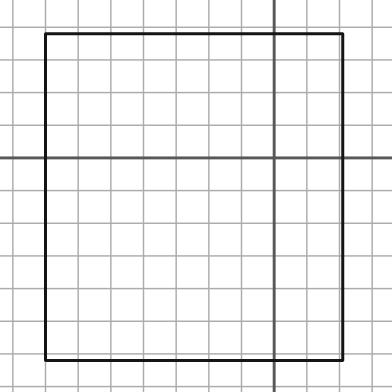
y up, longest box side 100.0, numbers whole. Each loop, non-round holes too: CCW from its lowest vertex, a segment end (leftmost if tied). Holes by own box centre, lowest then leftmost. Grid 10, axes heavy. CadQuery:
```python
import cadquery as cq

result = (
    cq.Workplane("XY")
    .moveTo(-70.0, -62.0)
    .lineTo(21.0, -62.0)
    .lineTo(21.0, 38.0)
    .lineTo(-70.0, 38.0)
    .close()
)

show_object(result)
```